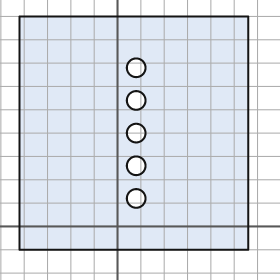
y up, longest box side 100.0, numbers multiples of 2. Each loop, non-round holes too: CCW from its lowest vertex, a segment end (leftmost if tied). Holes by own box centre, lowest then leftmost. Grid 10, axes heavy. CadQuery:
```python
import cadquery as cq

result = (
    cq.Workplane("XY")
    .moveTo(-42.0, -10.0)
    .lineTo(56.0, -10.0)
    .lineTo(56.0, 90.0)
    .lineTo(-42.0, 90.0)
    .close()
    .moveTo(8.0, 12.0)
    .circle(4.0)
    .moveTo(8.0, 26.0)
    .circle(4.0)
    .moveTo(8.0, 40.0)
    .circle(4.0)
    .moveTo(8.0, 54.0)
    .circle(4.0)
    .moveTo(8.0, 68.0)
    .circle(4.0)
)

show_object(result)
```